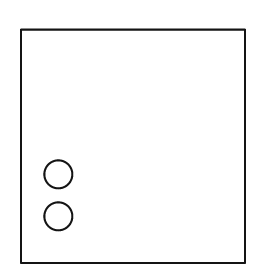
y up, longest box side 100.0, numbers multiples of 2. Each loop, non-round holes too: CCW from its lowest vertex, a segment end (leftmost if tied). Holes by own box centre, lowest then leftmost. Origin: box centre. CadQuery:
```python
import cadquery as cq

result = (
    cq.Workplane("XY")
    .moveTo(-48.0, -50.0)
    .lineTo(48.0, -50.0)
    .lineTo(48.0, 50.0)
    .lineTo(-48.0, 50.0)
    .close()
    .moveTo(-32.0, -30.0)
    .circle(6.0)
    .moveTo(-32.0, -12.0)
    .circle(6.0)
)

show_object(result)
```